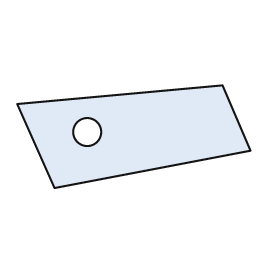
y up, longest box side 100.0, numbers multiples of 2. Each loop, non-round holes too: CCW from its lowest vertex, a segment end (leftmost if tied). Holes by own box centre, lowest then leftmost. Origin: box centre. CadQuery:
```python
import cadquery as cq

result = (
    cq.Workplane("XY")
    .moveTo(-34.0, -22.0)
    .lineTo(50.0, -6.0)
    .lineTo(38.0, 22.0)
    .lineTo(-50.0, 14.0)
    .close()
    .moveTo(-20.0, 2.0)
    .circle(6.0)
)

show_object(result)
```